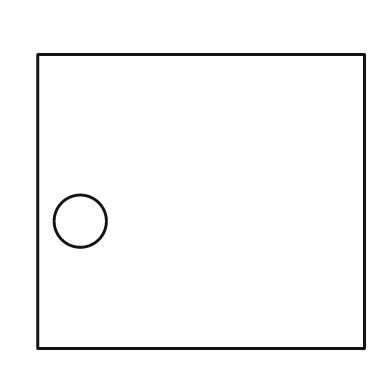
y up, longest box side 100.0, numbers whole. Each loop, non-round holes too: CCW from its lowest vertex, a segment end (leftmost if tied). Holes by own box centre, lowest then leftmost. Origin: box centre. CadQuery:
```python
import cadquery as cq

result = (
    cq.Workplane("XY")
    .moveTo(-50.0, -45.0)
    .lineTo(50.0, -45.0)
    .lineTo(50.0, 45.0)
    .lineTo(-50.0, 45.0)
    .close()
    .moveTo(-37.0, -6.0)
    .circle(8.0)
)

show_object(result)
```